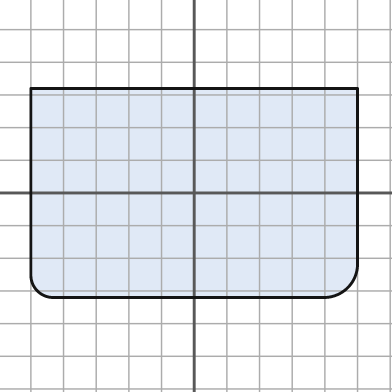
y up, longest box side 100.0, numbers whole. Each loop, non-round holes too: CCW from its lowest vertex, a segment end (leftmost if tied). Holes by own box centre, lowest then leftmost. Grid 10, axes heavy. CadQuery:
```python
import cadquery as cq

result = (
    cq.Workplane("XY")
    .moveTo(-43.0, -32.0)
    .lineTo(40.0, -32.0)
    .threePointArc((47.0, -29.0), (50.0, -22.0))
    .lineTo(50.0, 32.0)
    .lineTo(-50.0, 32.0)
    .lineTo(-50.0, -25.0)
    .threePointArc((-48.0, -30.0), (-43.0, -32.0))
    .close()
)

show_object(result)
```